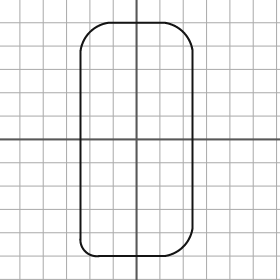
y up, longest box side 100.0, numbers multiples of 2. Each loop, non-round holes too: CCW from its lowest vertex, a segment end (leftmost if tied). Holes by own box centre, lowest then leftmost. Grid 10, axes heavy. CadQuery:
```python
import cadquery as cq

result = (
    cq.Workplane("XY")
    .moveTo(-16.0, -50.0)
    .lineTo(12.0, -50.0)
    .threePointArc((20.0, -46.0), (24.0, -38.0))
    .lineTo(24.0, 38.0)
    .threePointArc((20.0, 46.0), (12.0, 50.0))
    .lineTo(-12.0, 50.0)
    .threePointArc((-20.0, 46.0), (-24.0, 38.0))
    .lineTo(-24.0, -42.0)
    .threePointArc((-22.0, -48.0), (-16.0, -50.0))
    .close()
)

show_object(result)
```